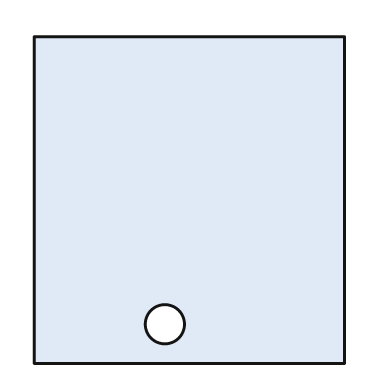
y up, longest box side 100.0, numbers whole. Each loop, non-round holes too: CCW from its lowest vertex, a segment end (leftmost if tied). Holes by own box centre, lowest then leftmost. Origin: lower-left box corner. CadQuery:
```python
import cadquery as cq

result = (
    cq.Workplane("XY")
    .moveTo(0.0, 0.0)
    .lineTo(95.0, 0.0)
    .lineTo(95.0, 100.0)
    .lineTo(0.0, 100.0)
    .close()
    .moveTo(40.0, 12.0)
    .circle(6.0)
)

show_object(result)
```